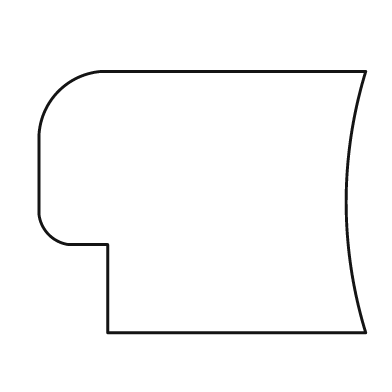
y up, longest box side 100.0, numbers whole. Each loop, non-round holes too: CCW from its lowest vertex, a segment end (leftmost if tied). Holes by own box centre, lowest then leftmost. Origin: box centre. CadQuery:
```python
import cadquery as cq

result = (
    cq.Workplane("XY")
    .moveTo(-29.0, -40.0)
    .lineTo(50.0, -40.0)
    .threePointArc((44.0, 0.0), (50.0, 40.0))
    .lineTo(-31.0, 40.0)
    .threePointArc((-44.0, 34.0), (-50.0, 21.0))
    .lineTo(-50.0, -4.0)
    .threePointArc((-47.0, -10.0), (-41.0, -13.0))
    .lineTo(-29.0, -13.0)
    .close()
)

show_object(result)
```